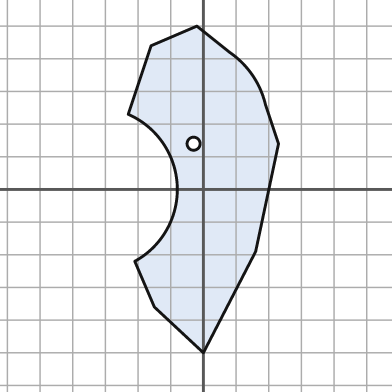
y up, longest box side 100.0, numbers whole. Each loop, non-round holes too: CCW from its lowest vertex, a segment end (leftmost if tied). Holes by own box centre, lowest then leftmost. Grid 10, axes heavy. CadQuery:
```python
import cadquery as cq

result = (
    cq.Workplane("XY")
    .moveTo(0.0, -50.0)
    .lineTo(16.0, -19.0)
    .lineTo(23.0, 14.0)
    .lineTo(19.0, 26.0)
    .threePointArc((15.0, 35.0), (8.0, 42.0))
    .lineTo(-2.0, 50.0)
    .lineTo(-16.0, 44.0)
    .lineTo(-23.0, 23.0)
    .threePointArc((-8.0, 1.0), (-21.0, -22.0))
    .lineTo(-15.0, -36.0)
    .close()
    .moveTo(-3.0, 14.0)
    .circle(2.0)
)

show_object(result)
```